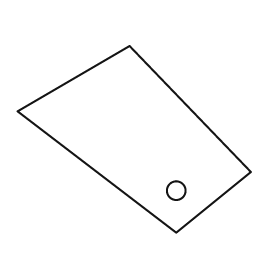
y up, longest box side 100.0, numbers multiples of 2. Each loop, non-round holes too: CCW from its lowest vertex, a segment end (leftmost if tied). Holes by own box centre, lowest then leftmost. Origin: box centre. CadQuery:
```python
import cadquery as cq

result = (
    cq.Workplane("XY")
    .moveTo(18.0, -40.0)
    .lineTo(50.0, -14.0)
    .lineTo(-2.0, 40.0)
    .lineTo(-50.0, 12.0)
    .close()
    .moveTo(18.0, -22.0)
    .circle(4.0)
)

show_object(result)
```